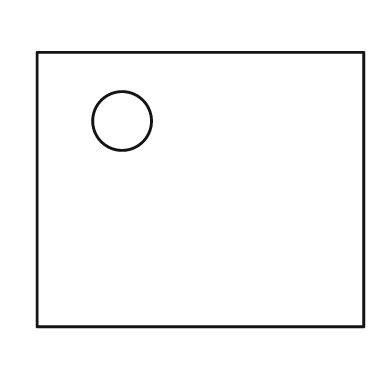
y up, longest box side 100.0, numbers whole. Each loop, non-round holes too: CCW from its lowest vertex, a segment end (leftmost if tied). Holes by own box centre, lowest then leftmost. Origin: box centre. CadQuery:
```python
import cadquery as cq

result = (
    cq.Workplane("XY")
    .moveTo(-50.0, -42.0)
    .lineTo(50.0, -42.0)
    .lineTo(50.0, 42.0)
    .lineTo(-50.0, 42.0)
    .close()
    .moveTo(-24.0, 21.0)
    .circle(9.0)
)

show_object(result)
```